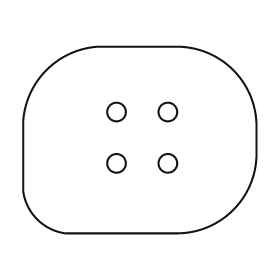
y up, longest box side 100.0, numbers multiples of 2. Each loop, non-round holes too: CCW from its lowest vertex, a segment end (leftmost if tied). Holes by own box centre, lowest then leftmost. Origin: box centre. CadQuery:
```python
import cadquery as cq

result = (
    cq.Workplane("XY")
    .moveTo(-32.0, -40.0)
    .lineTo(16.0, -40.0)
    .threePointArc((40.0, -30.0), (50.0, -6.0))
    .lineTo(50.0, 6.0)
    .threePointArc((40.0, 30.0), (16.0, 40.0))
    .lineTo(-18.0, 40.0)
    .threePointArc((-40.0, 30.0), (-50.0, 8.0))
    .lineTo(-50.0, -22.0)
    .threePointArc((-44.0, -34.0), (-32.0, -40.0))
    .close()
    .moveTo(-10.0, -10.0)
    .circle(4.0)
    .moveTo(12.0, -10.0)
    .circle(4.0)
    .moveTo(-10.0, 12.0)
    .circle(4.0)
    .moveTo(12.0, 12.0)
    .circle(4.0)
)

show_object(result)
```